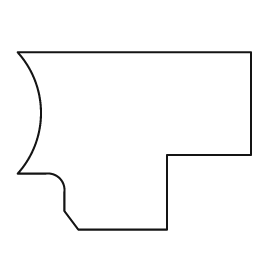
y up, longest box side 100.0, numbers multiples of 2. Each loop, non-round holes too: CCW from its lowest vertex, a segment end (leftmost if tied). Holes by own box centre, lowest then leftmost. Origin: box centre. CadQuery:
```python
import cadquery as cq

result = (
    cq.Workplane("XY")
    .moveTo(-24.0, -38.0)
    .lineTo(14.0, -38.0)
    .lineTo(14.0, -6.0)
    .lineTo(50.0, -6.0)
    .lineTo(50.0, 38.0)
    .lineTo(-50.0, 38.0)
    .threePointArc((-40.0, 12.0), (-50.0, -14.0))
    .lineTo(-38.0, -14.0)
    .threePointArc((-32.0, -16.0), (-30.0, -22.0))
    .lineTo(-30.0, -30.0)
    .close()
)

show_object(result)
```